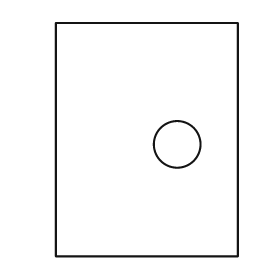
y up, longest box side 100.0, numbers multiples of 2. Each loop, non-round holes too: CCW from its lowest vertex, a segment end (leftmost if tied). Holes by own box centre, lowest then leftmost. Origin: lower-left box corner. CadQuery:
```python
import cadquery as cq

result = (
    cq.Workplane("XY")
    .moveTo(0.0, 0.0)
    .lineTo(78.0, 0.0)
    .lineTo(78.0, 100.0)
    .lineTo(0.0, 100.0)
    .close()
    .moveTo(52.0, 48.0)
    .circle(10.0)
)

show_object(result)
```